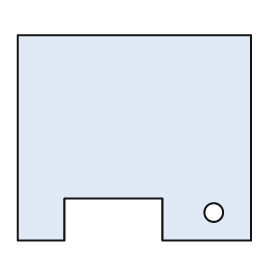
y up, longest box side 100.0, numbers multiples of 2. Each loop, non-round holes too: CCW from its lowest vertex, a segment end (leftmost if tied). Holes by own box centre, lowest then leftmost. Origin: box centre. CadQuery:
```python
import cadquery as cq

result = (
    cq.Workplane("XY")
    .moveTo(-50.0, -44.0)
    .lineTo(-30.0, -44.0)
    .lineTo(-30.0, -26.0)
    .lineTo(12.0, -26.0)
    .lineTo(12.0, -44.0)
    .lineTo(50.0, -44.0)
    .lineTo(50.0, 44.0)
    .lineTo(-50.0, 44.0)
    .close()
    .moveTo(34.0, -32.0)
    .circle(4.0)
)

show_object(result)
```